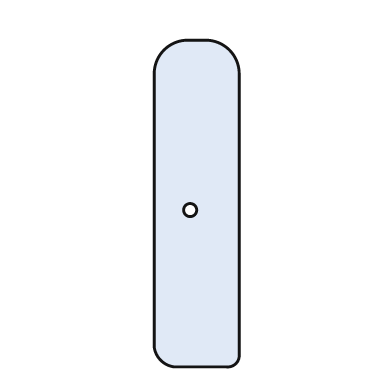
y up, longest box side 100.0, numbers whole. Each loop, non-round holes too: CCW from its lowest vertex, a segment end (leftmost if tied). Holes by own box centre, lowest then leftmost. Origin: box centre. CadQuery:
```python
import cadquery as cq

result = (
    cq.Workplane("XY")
    .moveTo(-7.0, -50.0)
    .lineTo(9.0, -50.0)
    .threePointArc((12.0, -49.0), (13.0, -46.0))
    .lineTo(13.0, 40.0)
    .threePointArc((10.0, 47.0), (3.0, 50.0))
    .lineTo(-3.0, 50.0)
    .threePointArc((-10.0, 47.0), (-13.0, 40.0))
    .lineTo(-13.0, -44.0)
    .threePointArc((-11.0, -48.0), (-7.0, -50.0))
    .close()
    .moveTo(-2.0, -2.0)
    .circle(2.0)
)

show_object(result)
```